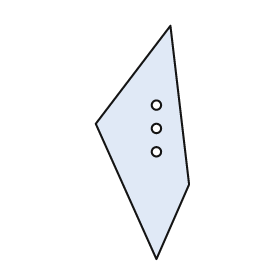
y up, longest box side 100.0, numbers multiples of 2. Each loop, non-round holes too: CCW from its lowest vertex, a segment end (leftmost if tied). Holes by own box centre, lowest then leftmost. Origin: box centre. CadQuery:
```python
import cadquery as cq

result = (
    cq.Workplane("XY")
    .moveTo(6.0, -50.0)
    .lineTo(20.0, -18.0)
    .lineTo(12.0, 50.0)
    .lineTo(-20.0, 8.0)
    .close()
    .moveTo(6.0, -4.0)
    .circle(2.0)
    .moveTo(6.0, 6.0)
    .circle(2.0)
    .moveTo(6.0, 16.0)
    .circle(2.0)
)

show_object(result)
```